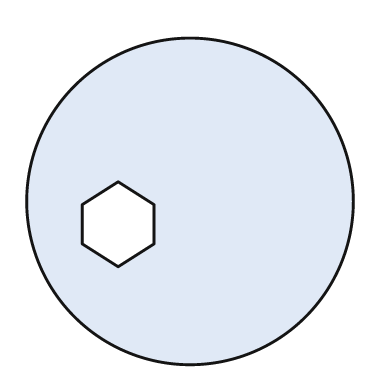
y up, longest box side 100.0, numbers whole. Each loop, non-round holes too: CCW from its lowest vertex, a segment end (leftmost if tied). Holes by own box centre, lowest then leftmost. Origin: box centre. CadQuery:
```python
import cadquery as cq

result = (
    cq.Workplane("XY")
    .moveTo(0.0, 0.0)
    .circle(50.0)
    .moveTo(-22.0, -20.0)
    .lineTo(-11.0, -13.0)
    .lineTo(-11.0, -1.0)
    .lineTo(-22.0, 6.0)
    .lineTo(-33.0, -1.0)
    .lineTo(-33.0, -13.0)
    .close()
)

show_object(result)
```